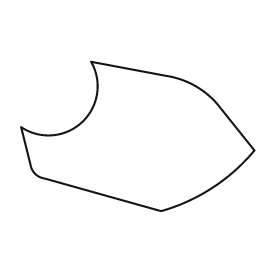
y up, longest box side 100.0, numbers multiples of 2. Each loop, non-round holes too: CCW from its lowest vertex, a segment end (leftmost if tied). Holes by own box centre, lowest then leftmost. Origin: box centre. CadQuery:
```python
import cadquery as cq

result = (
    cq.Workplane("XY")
    .moveTo(10.0, -32.0)
    .threePointArc((32.0, -22.0), (50.0, -6.0))
    .lineTo(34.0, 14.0)
    .threePointArc((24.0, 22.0), (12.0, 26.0))
    .lineTo(-20.0, 32.0)
    .threePointArc((-24.0, 6.0), (-50.0, 4.0))
    .lineTo(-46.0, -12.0)
    .threePointArc((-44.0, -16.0), (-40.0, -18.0))
    .close()
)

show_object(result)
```